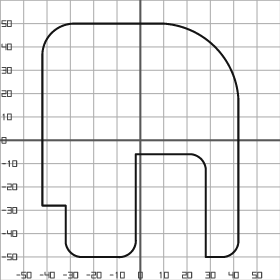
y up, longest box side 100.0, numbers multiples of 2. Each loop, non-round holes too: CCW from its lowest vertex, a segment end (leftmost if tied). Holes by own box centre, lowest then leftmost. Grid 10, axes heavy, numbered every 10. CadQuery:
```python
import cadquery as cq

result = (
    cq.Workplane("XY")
    .moveTo(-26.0, -50.0)
    .lineTo(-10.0, -50.0)
    .threePointArc((-4.0, -48.0), (-2.0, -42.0))
    .lineTo(-2.0, -6.0)
    .lineTo(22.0, -6.0)
    .threePointArc((26.0, -8.0), (28.0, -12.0))
    .lineTo(28.0, -50.0)
    .lineTo(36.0, -50.0)
    .threePointArc((40.0, -48.0), (42.0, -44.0))
    .lineTo(42.0, 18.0)
    .threePointArc((32.0, 40.0), (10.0, 50.0))
    .lineTo(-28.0, 50.0)
    .threePointArc((-38.0, 46.0), (-42.0, 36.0))
    .lineTo(-42.0, -28.0)
    .lineTo(-32.0, -28.0)
    .lineTo(-32.0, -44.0)
    .threePointArc((-30.0, -48.0), (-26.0, -50.0))
    .close()
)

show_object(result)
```